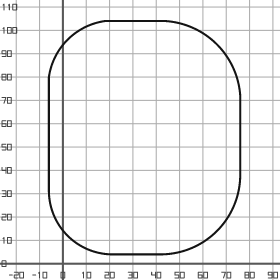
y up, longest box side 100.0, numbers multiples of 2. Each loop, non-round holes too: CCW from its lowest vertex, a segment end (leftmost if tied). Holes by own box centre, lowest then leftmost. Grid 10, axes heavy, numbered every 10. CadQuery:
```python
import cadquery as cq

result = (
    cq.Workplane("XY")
    .moveTo(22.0, 4.0)
    .lineTo(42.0, 4.0)
    .threePointArc((66.0, 14.0), (76.0, 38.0))
    .lineTo(76.0, 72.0)
    .threePointArc((66.0, 94.0), (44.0, 104.0))
    .lineTo(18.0, 104.0)
    .threePointArc((2.0, 96.0), (-6.0, 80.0))
    .lineTo(-6.0, 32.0)
    .threePointArc((2.0, 12.0), (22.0, 4.0))
    .close()
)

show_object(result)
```